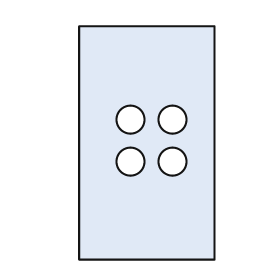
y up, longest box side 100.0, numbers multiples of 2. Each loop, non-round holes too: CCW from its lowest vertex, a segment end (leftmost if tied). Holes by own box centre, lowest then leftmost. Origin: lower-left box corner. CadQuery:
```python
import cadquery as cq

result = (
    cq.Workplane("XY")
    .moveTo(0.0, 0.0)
    .lineTo(58.0, 0.0)
    .lineTo(58.0, 100.0)
    .lineTo(0.0, 100.0)
    .close()
    .moveTo(22.0, 42.0)
    .circle(6.0)
    .moveTo(40.0, 42.0)
    .circle(6.0)
    .moveTo(22.0, 60.0)
    .circle(6.0)
    .moveTo(40.0, 60.0)
    .circle(6.0)
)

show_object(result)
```